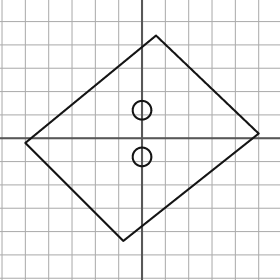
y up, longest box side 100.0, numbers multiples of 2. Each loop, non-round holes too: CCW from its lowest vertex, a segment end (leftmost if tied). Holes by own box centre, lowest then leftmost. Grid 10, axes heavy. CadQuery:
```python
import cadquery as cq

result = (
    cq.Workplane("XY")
    .moveTo(-8.0, -44.0)
    .lineTo(50.0, 2.0)
    .lineTo(6.0, 44.0)
    .lineTo(-50.0, -2.0)
    .close()
    .moveTo(0.0, -8.0)
    .circle(4.0)
    .moveTo(0.0, 12.0)
    .circle(4.0)
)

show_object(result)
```